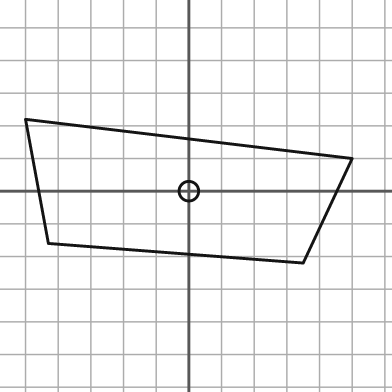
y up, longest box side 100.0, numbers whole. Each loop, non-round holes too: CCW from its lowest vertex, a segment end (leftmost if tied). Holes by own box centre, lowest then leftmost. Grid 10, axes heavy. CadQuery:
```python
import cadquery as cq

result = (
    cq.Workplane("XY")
    .moveTo(35.0, -22.0)
    .lineTo(50.0, 10.0)
    .lineTo(-50.0, 22.0)
    .lineTo(-43.0, -16.0)
    .close()
    .moveTo(0.0, 0.0)
    .circle(3.0)
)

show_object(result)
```